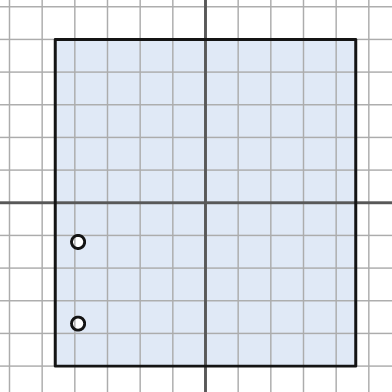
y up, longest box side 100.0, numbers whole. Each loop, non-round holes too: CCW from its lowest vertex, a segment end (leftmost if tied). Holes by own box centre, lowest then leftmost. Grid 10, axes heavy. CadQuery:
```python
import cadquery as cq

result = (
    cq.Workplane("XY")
    .moveTo(-46.0, -50.0)
    .lineTo(46.0, -50.0)
    .lineTo(46.0, 50.0)
    .lineTo(-46.0, 50.0)
    .close()
    .moveTo(-39.0, -37.0)
    .circle(2.0)
    .moveTo(-39.0, -12.0)
    .circle(2.0)
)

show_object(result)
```